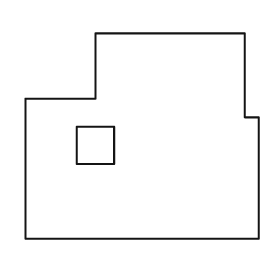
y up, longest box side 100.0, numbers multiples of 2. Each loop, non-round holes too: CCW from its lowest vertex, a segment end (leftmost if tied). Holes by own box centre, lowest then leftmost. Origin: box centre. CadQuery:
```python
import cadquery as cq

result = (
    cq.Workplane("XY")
    .moveTo(-50.0, -44.0)
    .lineTo(50.0, -44.0)
    .lineTo(50.0, 8.0)
    .lineTo(44.0, 8.0)
    .lineTo(44.0, 44.0)
    .lineTo(-20.0, 44.0)
    .lineTo(-20.0, 16.0)
    .lineTo(-50.0, 16.0)
    .close()
    .moveTo(-28.0, -12.0)
    .lineTo(-12.0, -12.0)
    .lineTo(-12.0, 4.0)
    .lineTo(-28.0, 4.0)
    .close()
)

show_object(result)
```